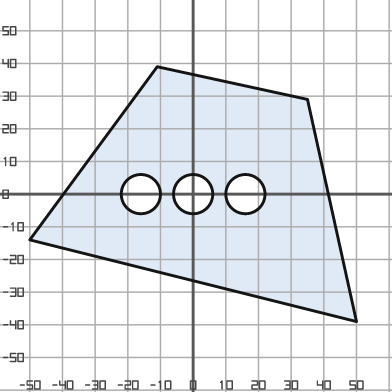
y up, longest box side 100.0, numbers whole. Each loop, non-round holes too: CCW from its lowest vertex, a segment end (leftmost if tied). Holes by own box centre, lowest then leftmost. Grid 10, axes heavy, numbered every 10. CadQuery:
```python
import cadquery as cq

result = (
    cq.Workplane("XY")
    .moveTo(50.0, -39.0)
    .lineTo(35.0, 29.0)
    .lineTo(-11.0, 39.0)
    .lineTo(-50.0, -14.0)
    .close()
    .moveTo(-16.0, 0.0)
    .circle(6.0)
    .moveTo(0.0, 0.0)
    .circle(6.0)
    .moveTo(16.0, 0.0)
    .circle(6.0)
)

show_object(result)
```